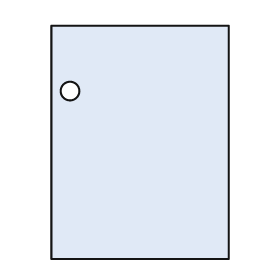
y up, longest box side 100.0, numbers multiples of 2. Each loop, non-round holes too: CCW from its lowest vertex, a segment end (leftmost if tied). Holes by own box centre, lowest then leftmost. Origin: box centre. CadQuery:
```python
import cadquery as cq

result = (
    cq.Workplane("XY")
    .moveTo(-38.0, -50.0)
    .lineTo(38.0, -50.0)
    .lineTo(38.0, 50.0)
    .lineTo(-38.0, 50.0)
    .close()
    .moveTo(-30.0, 22.0)
    .circle(4.0)
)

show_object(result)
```